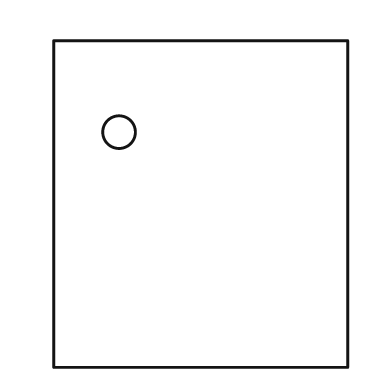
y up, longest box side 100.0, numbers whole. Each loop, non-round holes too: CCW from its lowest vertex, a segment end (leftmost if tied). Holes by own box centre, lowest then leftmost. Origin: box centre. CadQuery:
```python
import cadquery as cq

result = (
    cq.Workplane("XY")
    .moveTo(-45.0, -50.0)
    .lineTo(45.0, -50.0)
    .lineTo(45.0, 50.0)
    .lineTo(-45.0, 50.0)
    .close()
    .moveTo(-25.0, 22.0)
    .circle(5.0)
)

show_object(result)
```